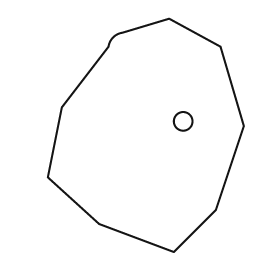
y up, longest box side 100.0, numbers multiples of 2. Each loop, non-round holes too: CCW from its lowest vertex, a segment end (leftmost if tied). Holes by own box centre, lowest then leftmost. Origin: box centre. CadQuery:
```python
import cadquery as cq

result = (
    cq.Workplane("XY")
    .moveTo(12.0, -50.0)
    .lineTo(30.0, -32.0)
    .lineTo(42.0, 4.0)
    .lineTo(32.0, 38.0)
    .lineTo(10.0, 50.0)
    .lineTo(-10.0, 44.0)
    .threePointArc((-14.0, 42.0), (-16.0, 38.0))
    .lineTo(-36.0, 12.0)
    .lineTo(-42.0, -18.0)
    .lineTo(-20.0, -38.0)
    .close()
    .moveTo(16.0, 6.0)
    .circle(4.0)
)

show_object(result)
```